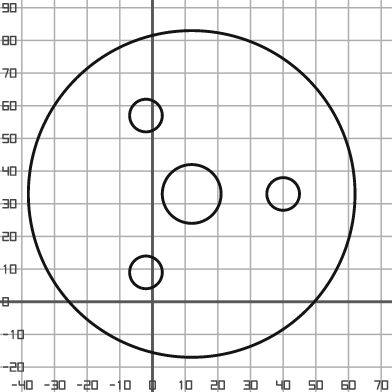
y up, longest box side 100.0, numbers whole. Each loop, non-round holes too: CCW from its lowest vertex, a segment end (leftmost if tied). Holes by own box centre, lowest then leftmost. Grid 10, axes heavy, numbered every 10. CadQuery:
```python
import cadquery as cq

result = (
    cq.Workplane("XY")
    .moveTo(12.0, 33.0)
    .circle(50.0)
    .moveTo(-2.0, 9.0)
    .circle(5.0)
    .moveTo(12.0, 33.0)
    .circle(9.0)
    .moveTo(40.0, 33.0)
    .circle(5.0)
    .moveTo(-2.0, 57.0)
    .circle(5.0)
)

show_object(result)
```